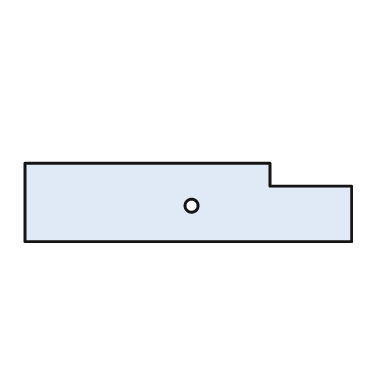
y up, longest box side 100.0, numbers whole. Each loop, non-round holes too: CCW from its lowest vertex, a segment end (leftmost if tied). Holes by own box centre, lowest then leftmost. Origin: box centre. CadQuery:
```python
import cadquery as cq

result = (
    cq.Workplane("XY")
    .moveTo(-50.0, -12.0)
    .lineTo(50.0, -12.0)
    .lineTo(50.0, 5.0)
    .lineTo(25.0, 5.0)
    .lineTo(25.0, 12.0)
    .lineTo(-50.0, 12.0)
    .close()
    .moveTo(1.0, -1.0)
    .circle(2.0)
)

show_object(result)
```